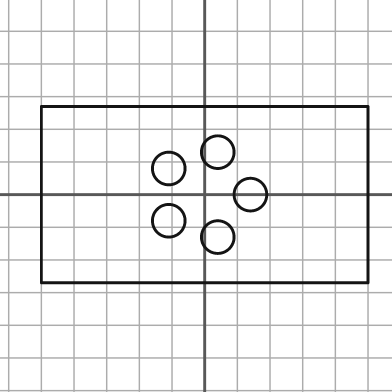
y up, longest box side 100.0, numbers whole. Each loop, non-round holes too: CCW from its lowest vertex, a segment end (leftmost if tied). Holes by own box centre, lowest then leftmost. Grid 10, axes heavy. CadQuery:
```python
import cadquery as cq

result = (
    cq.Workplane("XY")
    .moveTo(-50.0, -27.0)
    .lineTo(50.0, -27.0)
    .lineTo(50.0, 27.0)
    .lineTo(-50.0, 27.0)
    .close()
    .moveTo(4.0, -13.0)
    .circle(5.0)
    .moveTo(-11.0, -8.0)
    .circle(5.0)
    .moveTo(14.0, 0.0)
    .circle(5.0)
    .moveTo(-11.0, 8.0)
    .circle(5.0)
    .moveTo(4.0, 13.0)
    .circle(5.0)
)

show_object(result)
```